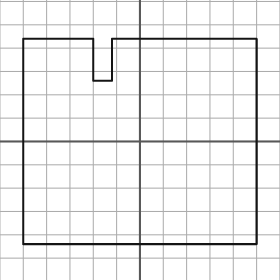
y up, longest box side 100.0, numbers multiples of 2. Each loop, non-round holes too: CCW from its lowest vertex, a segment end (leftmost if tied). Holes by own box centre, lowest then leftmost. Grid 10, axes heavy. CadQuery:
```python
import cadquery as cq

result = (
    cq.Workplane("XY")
    .moveTo(-50.0, -44.0)
    .lineTo(50.0, -44.0)
    .lineTo(50.0, 44.0)
    .lineTo(-12.0, 44.0)
    .lineTo(-12.0, 26.0)
    .lineTo(-20.0, 26.0)
    .lineTo(-20.0, 44.0)
    .lineTo(-50.0, 44.0)
    .close()
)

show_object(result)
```